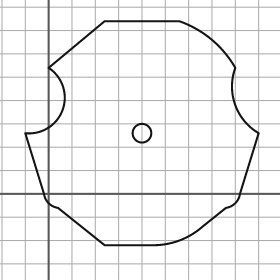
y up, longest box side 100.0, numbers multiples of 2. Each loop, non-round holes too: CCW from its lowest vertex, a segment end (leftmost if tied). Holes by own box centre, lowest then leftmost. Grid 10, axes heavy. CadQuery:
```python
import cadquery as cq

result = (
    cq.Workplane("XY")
    .moveTo(24.0, -22.0)
    .lineTo(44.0, -22.0)
    .threePointArc((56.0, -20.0), (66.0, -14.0))
    .lineTo(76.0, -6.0)
    .threePointArc((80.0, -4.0), (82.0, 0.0))
    .lineTo(90.0, 26.0)
    .threePointArc((80.0, 38.0), (80.0, 54.0))
    .threePointArc((70.0, 66.0), (56.0, 74.0))
    .lineTo(24.0, 74.0)
    .lineTo(0.0, 54.0)
    .threePointArc((6.0, 36.0), (-10.0, 26.0))
    .lineTo(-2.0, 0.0)
    .threePointArc((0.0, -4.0), (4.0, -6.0))
    .close()
    .moveTo(40.0, 26.0)
    .circle(4.0)
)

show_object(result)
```